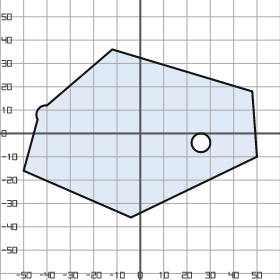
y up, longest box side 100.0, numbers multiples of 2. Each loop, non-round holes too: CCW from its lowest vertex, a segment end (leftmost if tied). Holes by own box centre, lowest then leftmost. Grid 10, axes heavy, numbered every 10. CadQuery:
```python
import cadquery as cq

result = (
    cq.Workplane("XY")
    .moveTo(-4.0, -36.0)
    .lineTo(50.0, -10.0)
    .lineTo(48.0, 18.0)
    .lineTo(-12.0, 36.0)
    .lineTo(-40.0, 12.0)
    .threePointArc((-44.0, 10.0), (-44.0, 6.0))
    .lineTo(-50.0, -16.0)
    .close()
    .moveTo(26.0, -4.0)
    .circle(4.0)
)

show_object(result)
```